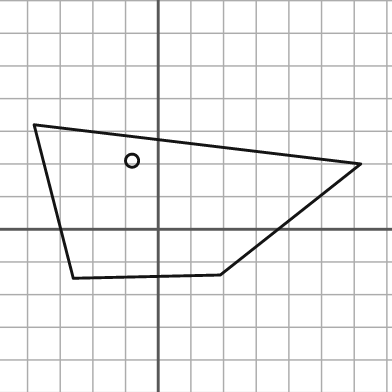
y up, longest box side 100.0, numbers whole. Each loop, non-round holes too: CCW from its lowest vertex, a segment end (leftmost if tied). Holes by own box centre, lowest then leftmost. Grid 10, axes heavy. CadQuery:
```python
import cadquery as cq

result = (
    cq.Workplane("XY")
    .moveTo(-26.0, -15.0)
    .lineTo(19.0, -14.0)
    .lineTo(62.0, 20.0)
    .lineTo(-38.0, 32.0)
    .close()
    .moveTo(-8.0, 21.0)
    .circle(2.0)
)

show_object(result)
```